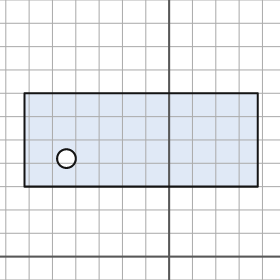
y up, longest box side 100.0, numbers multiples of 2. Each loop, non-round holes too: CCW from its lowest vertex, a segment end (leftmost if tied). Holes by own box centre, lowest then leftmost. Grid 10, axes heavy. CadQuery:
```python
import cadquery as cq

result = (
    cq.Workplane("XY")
    .moveTo(-62.0, 30.0)
    .lineTo(38.0, 30.0)
    .lineTo(38.0, 70.0)
    .lineTo(-62.0, 70.0)
    .close()
    .moveTo(-44.0, 42.0)
    .circle(4.0)
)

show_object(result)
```